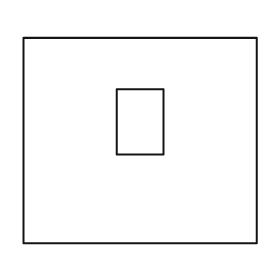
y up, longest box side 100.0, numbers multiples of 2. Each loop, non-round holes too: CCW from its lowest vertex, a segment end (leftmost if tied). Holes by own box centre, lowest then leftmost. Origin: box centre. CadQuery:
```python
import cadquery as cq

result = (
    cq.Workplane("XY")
    .moveTo(-50.0, -44.0)
    .lineTo(50.0, -44.0)
    .lineTo(50.0, 44.0)
    .lineTo(-50.0, 44.0)
    .close()
    .moveTo(-10.0, -6.0)
    .lineTo(10.0, -6.0)
    .lineTo(10.0, 22.0)
    .lineTo(-10.0, 22.0)
    .close()
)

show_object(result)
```